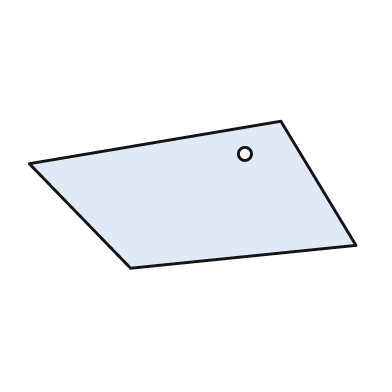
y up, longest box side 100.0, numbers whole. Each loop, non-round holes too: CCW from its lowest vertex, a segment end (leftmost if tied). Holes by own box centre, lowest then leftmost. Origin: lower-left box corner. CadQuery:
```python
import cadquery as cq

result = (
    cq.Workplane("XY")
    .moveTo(31.0, 0.0)
    .lineTo(100.0, 7.0)
    .lineTo(77.0, 45.0)
    .lineTo(0.0, 32.0)
    .close()
    .moveTo(66.0, 35.0)
    .circle(2.0)
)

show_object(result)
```